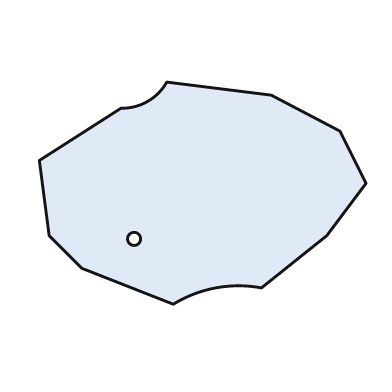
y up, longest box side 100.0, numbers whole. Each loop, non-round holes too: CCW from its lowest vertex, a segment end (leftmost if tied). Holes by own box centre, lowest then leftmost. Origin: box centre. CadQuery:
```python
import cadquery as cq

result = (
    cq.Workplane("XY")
    .moveTo(-9.0, -34.0)
    .threePointArc((4.0, -29.0), (18.0, -29.0))
    .lineTo(38.0, -13.0)
    .lineTo(50.0, 3.0)
    .lineTo(42.0, 19.0)
    .lineTo(21.0, 30.0)
    .lineTo(-11.0, 34.0)
    .threePointArc((-17.0, 28.0), (-25.0, 26.0))
    .lineTo(-50.0, 10.0)
    .lineTo(-47.0, -13.0)
    .lineTo(-37.0, -23.0)
    .close()
    .moveTo(-21.0, -14.0)
    .circle(2.0)
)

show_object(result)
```